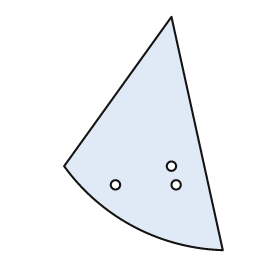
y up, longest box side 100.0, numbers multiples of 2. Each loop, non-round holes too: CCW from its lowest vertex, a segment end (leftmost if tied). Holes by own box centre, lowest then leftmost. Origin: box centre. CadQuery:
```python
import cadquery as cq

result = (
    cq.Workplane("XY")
    .moveTo(34.0, -50.0)
    .lineTo(12.0, 50.0)
    .lineTo(-34.0, -14.0)
    .threePointArc((-4.0, -40.0), (34.0, -50.0))
    .close()
    .moveTo(-12.0, -22.0)
    .circle(2.0)
    .moveTo(14.0, -22.0)
    .circle(2.0)
    .moveTo(12.0, -14.0)
    .circle(2.0)
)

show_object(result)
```